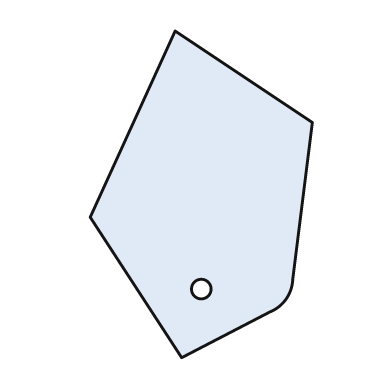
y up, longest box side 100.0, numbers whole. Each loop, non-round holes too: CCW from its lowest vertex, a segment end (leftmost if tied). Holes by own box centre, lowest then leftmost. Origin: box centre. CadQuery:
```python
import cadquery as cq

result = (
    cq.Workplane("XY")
    .moveTo(-6.0, -50.0)
    .lineTo(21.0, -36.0)
    .threePointArc((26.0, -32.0), (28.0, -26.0))
    .lineTo(34.0, 22.0)
    .lineTo(-8.0, 50.0)
    .lineTo(-34.0, -7.0)
    .close()
    .moveTo(0.0, -29.0)
    .circle(3.0)
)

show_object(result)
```